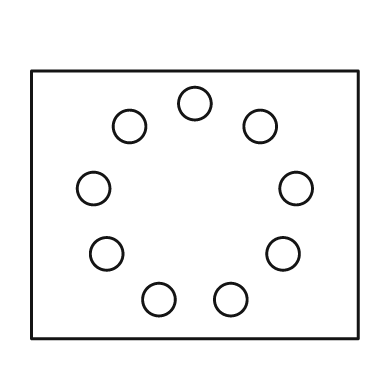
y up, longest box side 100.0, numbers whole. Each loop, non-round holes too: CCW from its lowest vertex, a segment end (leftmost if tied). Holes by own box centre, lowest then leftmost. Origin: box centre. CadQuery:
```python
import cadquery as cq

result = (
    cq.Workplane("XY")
    .moveTo(-50.0, -41.0)
    .lineTo(50.0, -41.0)
    .lineTo(50.0, 41.0)
    .lineTo(-50.0, 41.0)
    .close()
    .moveTo(-11.0, -29.0)
    .circle(5.0)
    .moveTo(11.0, -29.0)
    .circle(5.0)
    .moveTo(-27.0, -15.0)
    .circle(5.0)
    .moveTo(27.0, -15.0)
    .circle(5.0)
    .moveTo(-31.0, 5.0)
    .circle(5.0)
    .moveTo(31.0, 5.0)
    .circle(5.0)
    .moveTo(-20.0, 24.0)
    .circle(5.0)
    .moveTo(20.0, 24.0)
    .circle(5.0)
    .moveTo(0.0, 31.0)
    .circle(5.0)
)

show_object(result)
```